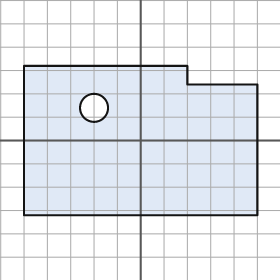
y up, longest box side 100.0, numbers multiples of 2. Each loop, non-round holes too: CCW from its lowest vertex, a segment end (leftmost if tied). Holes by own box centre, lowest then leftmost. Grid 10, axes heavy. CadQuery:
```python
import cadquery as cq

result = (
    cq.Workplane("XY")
    .moveTo(-50.0, -32.0)
    .lineTo(50.0, -32.0)
    .lineTo(50.0, 24.0)
    .lineTo(20.0, 24.0)
    .lineTo(20.0, 32.0)
    .lineTo(-50.0, 32.0)
    .close()
    .moveTo(-20.0, 14.0)
    .circle(6.0)
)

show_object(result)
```